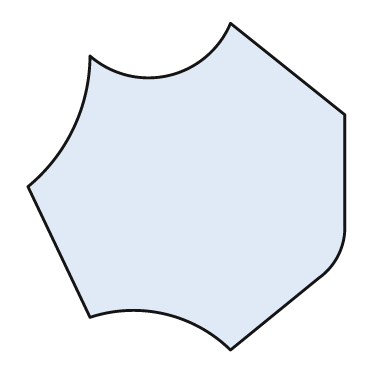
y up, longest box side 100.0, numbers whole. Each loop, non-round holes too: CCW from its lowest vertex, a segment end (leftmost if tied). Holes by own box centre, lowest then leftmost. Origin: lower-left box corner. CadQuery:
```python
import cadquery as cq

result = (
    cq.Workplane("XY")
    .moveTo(62.0, 0.0)
    .lineTo(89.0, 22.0)
    .threePointArc((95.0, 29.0), (97.0, 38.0))
    .lineTo(97.0, 72.0)
    .lineTo(62.0, 100.0)
    .threePointArc((43.0, 84.0), (19.0, 90.0))
    .threePointArc((14.0, 68.0), (0.0, 50.0))
    .lineTo(19.0, 10.0)
    .threePointArc((42.0, 11.0), (62.0, 0.0))
    .close()
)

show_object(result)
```